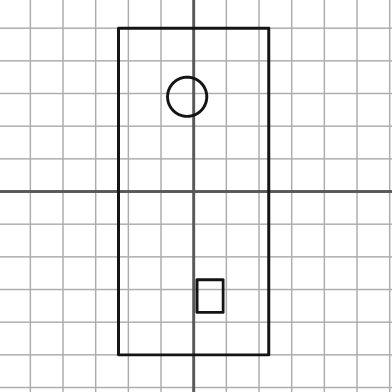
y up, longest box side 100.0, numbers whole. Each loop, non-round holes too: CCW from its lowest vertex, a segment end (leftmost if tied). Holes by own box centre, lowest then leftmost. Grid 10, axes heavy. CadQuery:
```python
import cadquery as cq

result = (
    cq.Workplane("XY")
    .moveTo(-23.0, -50.0)
    .lineTo(23.0, -50.0)
    .lineTo(23.0, 50.0)
    .lineTo(-23.0, 50.0)
    .close()
    .moveTo(1.0, -37.0)
    .lineTo(9.0, -37.0)
    .lineTo(9.0, -27.0)
    .lineTo(1.0, -27.0)
    .close()
    .moveTo(-2.0, 29.0)
    .circle(6.0)
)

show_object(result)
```